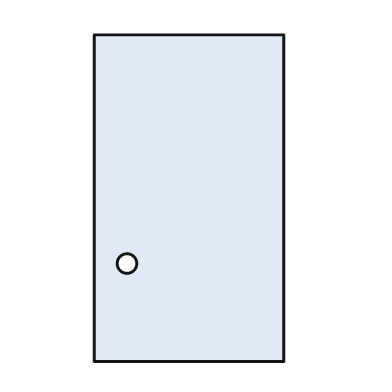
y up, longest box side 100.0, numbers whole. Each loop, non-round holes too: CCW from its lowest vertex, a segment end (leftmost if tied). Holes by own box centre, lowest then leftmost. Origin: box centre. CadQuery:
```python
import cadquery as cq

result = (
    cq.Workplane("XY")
    .moveTo(-29.0, -50.0)
    .lineTo(29.0, -50.0)
    .lineTo(29.0, 50.0)
    .lineTo(-29.0, 50.0)
    .close()
    .moveTo(-19.0, -20.0)
    .circle(3.0)
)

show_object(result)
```